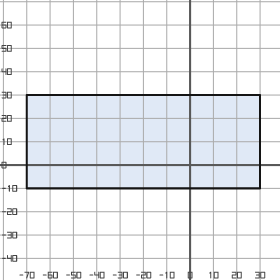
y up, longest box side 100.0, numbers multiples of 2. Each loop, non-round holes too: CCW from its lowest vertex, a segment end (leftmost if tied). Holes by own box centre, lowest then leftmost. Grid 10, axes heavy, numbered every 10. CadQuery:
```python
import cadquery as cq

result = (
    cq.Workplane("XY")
    .moveTo(-70.0, -10.0)
    .lineTo(30.0, -10.0)
    .lineTo(30.0, 30.0)
    .lineTo(-70.0, 30.0)
    .close()
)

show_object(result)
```